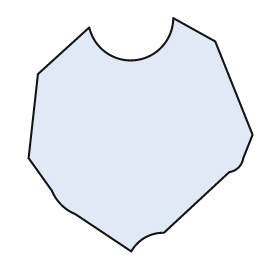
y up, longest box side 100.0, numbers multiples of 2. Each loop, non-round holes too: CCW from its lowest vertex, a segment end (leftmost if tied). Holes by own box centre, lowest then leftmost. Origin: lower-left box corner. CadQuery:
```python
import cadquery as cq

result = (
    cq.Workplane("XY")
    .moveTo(44.0, 0.0)
    .threePointArc((50.0, 6.0), (58.0, 8.0))
    .lineTo(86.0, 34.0)
    .threePointArc((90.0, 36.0), (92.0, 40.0))
    .lineTo(96.0, 50.0)
    .lineTo(80.0, 90.0)
    .lineTo(62.0, 100.0)
    .threePointArc((46.0, 82.0), (26.0, 96.0))
    .lineTo(4.0, 76.0)
    .lineTo(0.0, 40.0)
    .lineTo(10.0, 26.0)
    .threePointArc((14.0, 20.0), (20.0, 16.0))
    .close()
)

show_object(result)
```